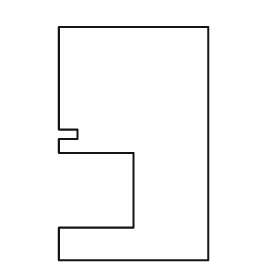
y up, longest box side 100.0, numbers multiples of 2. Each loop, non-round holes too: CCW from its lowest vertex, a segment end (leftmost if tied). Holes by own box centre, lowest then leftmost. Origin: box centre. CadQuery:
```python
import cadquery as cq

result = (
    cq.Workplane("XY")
    .moveTo(-32.0, -50.0)
    .lineTo(32.0, -50.0)
    .lineTo(32.0, 50.0)
    .lineTo(-32.0, 50.0)
    .lineTo(-32.0, 6.0)
    .lineTo(-24.0, 6.0)
    .lineTo(-24.0, 2.0)
    .lineTo(-32.0, 2.0)
    .lineTo(-32.0, -4.0)
    .lineTo(0.0, -4.0)
    .lineTo(0.0, -36.0)
    .lineTo(-32.0, -36.0)
    .close()
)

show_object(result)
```